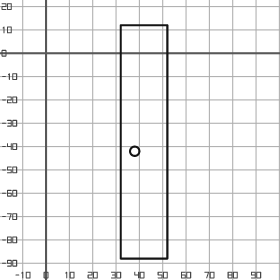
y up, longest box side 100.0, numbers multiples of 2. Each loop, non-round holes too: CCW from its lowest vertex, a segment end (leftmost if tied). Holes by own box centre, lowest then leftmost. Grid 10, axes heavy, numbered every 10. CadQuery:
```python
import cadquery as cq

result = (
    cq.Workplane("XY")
    .moveTo(32.0, -88.0)
    .lineTo(52.0, -88.0)
    .lineTo(52.0, 12.0)
    .lineTo(32.0, 12.0)
    .close()
    .moveTo(38.0, -42.0)
    .circle(2.0)
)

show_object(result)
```